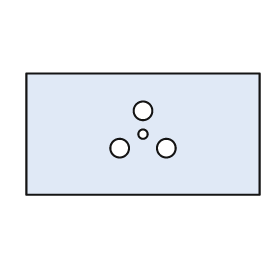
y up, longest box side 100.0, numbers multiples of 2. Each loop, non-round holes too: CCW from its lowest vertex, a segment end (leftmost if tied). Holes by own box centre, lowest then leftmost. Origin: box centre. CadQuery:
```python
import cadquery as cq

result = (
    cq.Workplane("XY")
    .moveTo(-50.0, -26.0)
    .lineTo(50.0, -26.0)
    .lineTo(50.0, 26.0)
    .lineTo(-50.0, 26.0)
    .close()
    .moveTo(-10.0, -6.0)
    .circle(4.0)
    .moveTo(10.0, -6.0)
    .circle(4.0)
    .moveTo(0.0, 0.0)
    .circle(2.0)
    .moveTo(0.0, 10.0)
    .circle(4.0)
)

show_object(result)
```